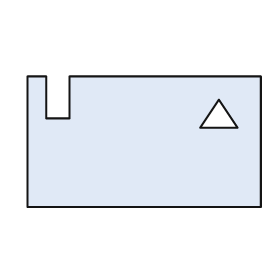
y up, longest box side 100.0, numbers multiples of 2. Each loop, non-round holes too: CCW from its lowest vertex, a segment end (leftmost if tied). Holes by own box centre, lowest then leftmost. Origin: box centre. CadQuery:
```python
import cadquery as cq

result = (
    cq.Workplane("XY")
    .moveTo(-50.0, -28.0)
    .lineTo(50.0, -28.0)
    .lineTo(50.0, 28.0)
    .lineTo(-32.0, 28.0)
    .lineTo(-32.0, 10.0)
    .lineTo(-42.0, 10.0)
    .lineTo(-42.0, 28.0)
    .lineTo(-50.0, 28.0)
    .close()
    .moveTo(24.0, 6.0)
    .lineTo(40.0, 6.0)
    .lineTo(32.0, 18.0)
    .close()
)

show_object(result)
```